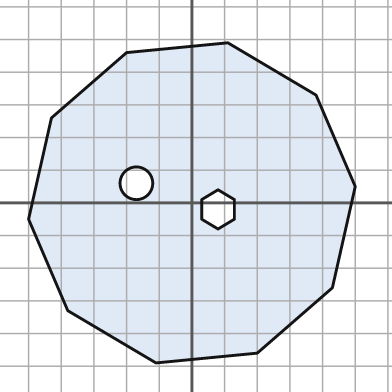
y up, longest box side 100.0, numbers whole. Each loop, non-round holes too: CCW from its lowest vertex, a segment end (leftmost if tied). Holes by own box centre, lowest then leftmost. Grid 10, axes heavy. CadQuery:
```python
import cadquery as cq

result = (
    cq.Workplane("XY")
    .moveTo(-11.0, -49.0)
    .lineTo(20.0, -46.0)
    .lineTo(43.0, -26.0)
    .lineTo(50.0, 5.0)
    .lineTo(38.0, 33.0)
    .lineTo(11.0, 49.0)
    .lineTo(-20.0, 46.0)
    .lineTo(-43.0, 26.0)
    .lineTo(-50.0, -5.0)
    .lineTo(-38.0, -33.0)
    .close()
    .moveTo(8.0, -8.0)
    .lineTo(13.0, -5.0)
    .lineTo(13.0, 1.0)
    .lineTo(8.0, 4.0)
    .lineTo(3.0, 1.0)
    .lineTo(3.0, -5.0)
    .close()
    .moveTo(-17.0, 6.0)
    .circle(5.0)
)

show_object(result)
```